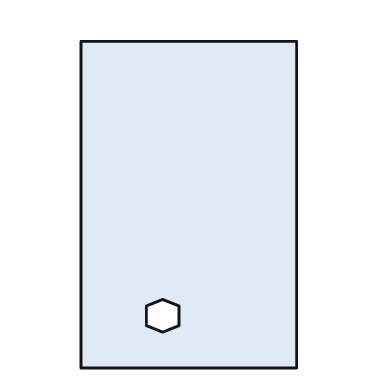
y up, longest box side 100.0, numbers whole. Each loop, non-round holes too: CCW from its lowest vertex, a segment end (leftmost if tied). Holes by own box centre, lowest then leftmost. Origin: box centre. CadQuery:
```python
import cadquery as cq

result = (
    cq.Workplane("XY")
    .moveTo(-33.0, -50.0)
    .lineTo(33.0, -50.0)
    .lineTo(33.0, 50.0)
    .lineTo(-33.0, 50.0)
    .close()
    .moveTo(-8.0, -39.0)
    .lineTo(-3.0, -37.0)
    .lineTo(-3.0, -31.0)
    .lineTo(-8.0, -29.0)
    .lineTo(-13.0, -31.0)
    .lineTo(-13.0, -37.0)
    .close()
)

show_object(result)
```